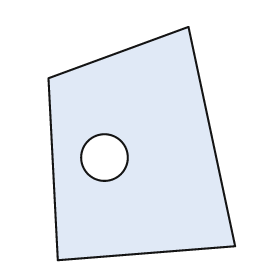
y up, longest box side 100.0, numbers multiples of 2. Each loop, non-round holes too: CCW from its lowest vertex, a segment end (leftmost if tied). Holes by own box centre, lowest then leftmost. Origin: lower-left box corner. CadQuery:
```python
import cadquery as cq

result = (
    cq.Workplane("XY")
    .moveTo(4.0, 0.0)
    .lineTo(80.0, 6.0)
    .lineTo(60.0, 100.0)
    .lineTo(0.0, 78.0)
    .close()
    .moveTo(24.0, 44.0)
    .circle(10.0)
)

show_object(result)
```